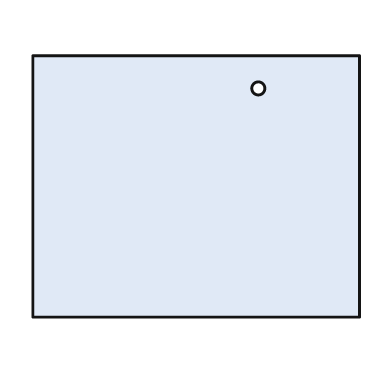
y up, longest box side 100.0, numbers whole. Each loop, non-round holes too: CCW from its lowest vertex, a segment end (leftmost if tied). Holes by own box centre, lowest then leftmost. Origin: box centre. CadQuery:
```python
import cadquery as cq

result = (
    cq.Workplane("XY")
    .moveTo(-50.0, -40.0)
    .lineTo(50.0, -40.0)
    .lineTo(50.0, 40.0)
    .lineTo(-50.0, 40.0)
    .close()
    .moveTo(19.0, 30.0)
    .circle(2.0)
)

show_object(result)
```